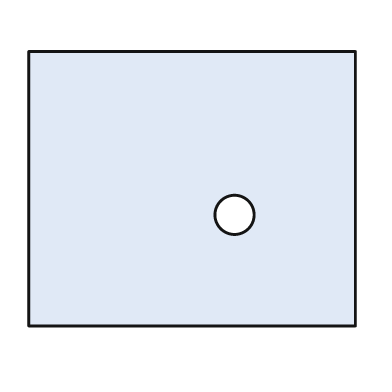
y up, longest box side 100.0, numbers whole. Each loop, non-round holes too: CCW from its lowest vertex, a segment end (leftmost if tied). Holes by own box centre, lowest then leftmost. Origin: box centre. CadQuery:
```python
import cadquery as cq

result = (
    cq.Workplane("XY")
    .moveTo(-50.0, -42.0)
    .lineTo(50.0, -42.0)
    .lineTo(50.0, 42.0)
    .lineTo(-50.0, 42.0)
    .close()
    .moveTo(13.0, -8.0)
    .circle(6.0)
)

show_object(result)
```